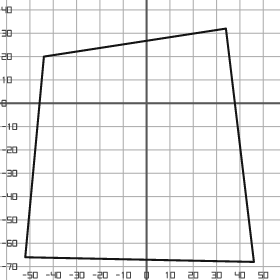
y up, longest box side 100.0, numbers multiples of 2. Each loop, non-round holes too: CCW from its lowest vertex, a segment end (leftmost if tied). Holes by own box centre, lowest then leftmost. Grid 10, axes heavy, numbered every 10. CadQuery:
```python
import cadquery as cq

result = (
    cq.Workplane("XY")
    .moveTo(46.0, -68.0)
    .lineTo(34.0, 32.0)
    .lineTo(-44.0, 20.0)
    .lineTo(-52.0, -66.0)
    .close()
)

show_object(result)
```